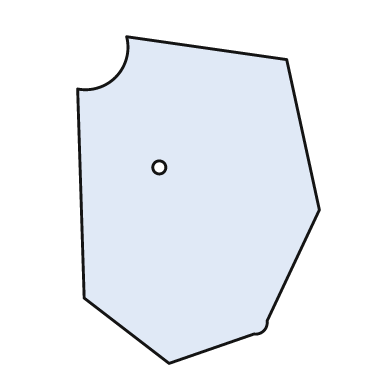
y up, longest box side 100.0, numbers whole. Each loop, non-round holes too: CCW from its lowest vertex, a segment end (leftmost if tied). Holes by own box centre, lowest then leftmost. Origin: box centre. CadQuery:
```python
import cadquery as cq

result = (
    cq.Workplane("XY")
    .moveTo(-9.0, -50.0)
    .lineTo(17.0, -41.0)
    .threePointArc((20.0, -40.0), (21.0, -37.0))
    .lineTo(37.0, -3.0)
    .lineTo(27.0, 43.0)
    .lineTo(-22.0, 50.0)
    .threePointArc((-25.0, 38.0), (-37.0, 34.0))
    .lineTo(-35.0, -30.0)
    .close()
    .moveTo(-12.0, 10.0)
    .circle(2.0)
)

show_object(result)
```